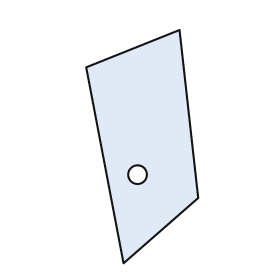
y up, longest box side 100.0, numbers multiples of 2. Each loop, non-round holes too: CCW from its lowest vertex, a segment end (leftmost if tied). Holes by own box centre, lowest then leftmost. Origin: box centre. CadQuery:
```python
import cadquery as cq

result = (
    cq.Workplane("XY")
    .moveTo(-8.0, -50.0)
    .lineTo(24.0, -22.0)
    .lineTo(16.0, 50.0)
    .lineTo(-24.0, 34.0)
    .close()
    .moveTo(-2.0, -12.0)
    .circle(4.0)
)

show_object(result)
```